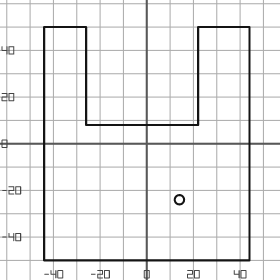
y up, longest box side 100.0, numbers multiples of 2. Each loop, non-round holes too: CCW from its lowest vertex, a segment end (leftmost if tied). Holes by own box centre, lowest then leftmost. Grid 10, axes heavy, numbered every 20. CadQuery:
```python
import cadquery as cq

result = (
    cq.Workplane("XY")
    .moveTo(-44.0, -50.0)
    .lineTo(44.0, -50.0)
    .lineTo(44.0, 50.0)
    .lineTo(22.0, 50.0)
    .lineTo(22.0, 8.0)
    .lineTo(-26.0, 8.0)
    .lineTo(-26.0, 50.0)
    .lineTo(-44.0, 50.0)
    .close()
    .moveTo(14.0, -24.0)
    .circle(2.0)
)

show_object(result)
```